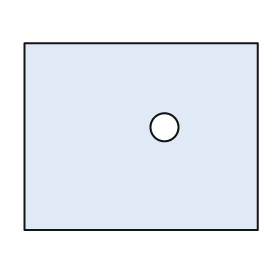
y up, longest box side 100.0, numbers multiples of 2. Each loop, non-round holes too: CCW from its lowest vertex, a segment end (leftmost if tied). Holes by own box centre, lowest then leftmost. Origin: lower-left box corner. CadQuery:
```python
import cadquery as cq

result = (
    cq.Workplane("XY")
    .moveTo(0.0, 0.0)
    .lineTo(100.0, 0.0)
    .lineTo(100.0, 80.0)
    .lineTo(0.0, 80.0)
    .close()
    .moveTo(60.0, 44.0)
    .circle(6.0)
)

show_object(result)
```